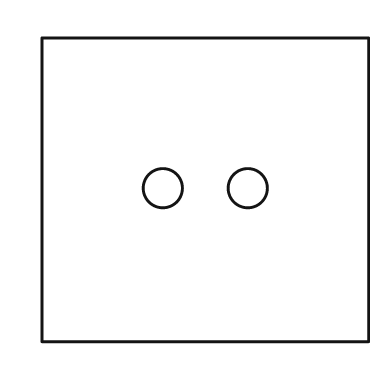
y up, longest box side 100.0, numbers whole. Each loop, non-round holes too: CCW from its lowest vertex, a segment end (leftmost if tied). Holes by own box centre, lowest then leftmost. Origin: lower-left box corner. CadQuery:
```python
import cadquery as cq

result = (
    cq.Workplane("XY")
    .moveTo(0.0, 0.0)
    .lineTo(100.0, 0.0)
    .lineTo(100.0, 93.0)
    .lineTo(0.0, 93.0)
    .close()
    .moveTo(37.0, 47.0)
    .circle(6.0)
    .moveTo(63.0, 47.0)
    .circle(6.0)
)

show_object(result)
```